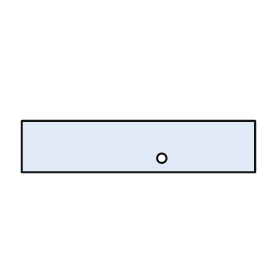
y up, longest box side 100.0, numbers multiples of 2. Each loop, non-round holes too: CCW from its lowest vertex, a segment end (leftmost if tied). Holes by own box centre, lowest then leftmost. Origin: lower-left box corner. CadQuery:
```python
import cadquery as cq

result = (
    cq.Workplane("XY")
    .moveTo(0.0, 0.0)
    .lineTo(100.0, 0.0)
    .lineTo(100.0, 22.0)
    .lineTo(0.0, 22.0)
    .close()
    .moveTo(60.0, 6.0)
    .circle(2.0)
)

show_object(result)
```